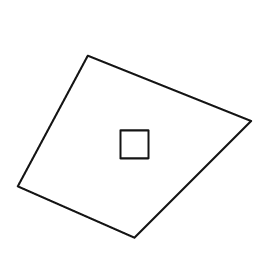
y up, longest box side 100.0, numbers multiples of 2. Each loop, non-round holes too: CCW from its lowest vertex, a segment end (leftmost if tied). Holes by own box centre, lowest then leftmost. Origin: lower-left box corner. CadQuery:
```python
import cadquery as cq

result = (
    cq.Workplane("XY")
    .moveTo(50.0, 0.0)
    .lineTo(100.0, 50.0)
    .lineTo(30.0, 78.0)
    .lineTo(0.0, 22.0)
    .close()
    .moveTo(44.0, 34.0)
    .lineTo(56.0, 34.0)
    .lineTo(56.0, 46.0)
    .lineTo(44.0, 46.0)
    .close()
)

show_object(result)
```